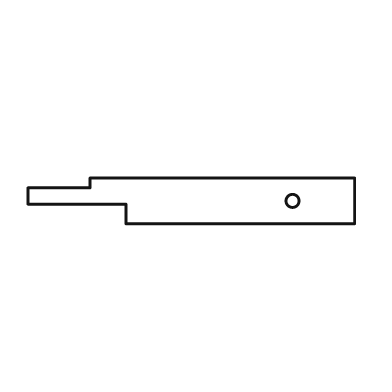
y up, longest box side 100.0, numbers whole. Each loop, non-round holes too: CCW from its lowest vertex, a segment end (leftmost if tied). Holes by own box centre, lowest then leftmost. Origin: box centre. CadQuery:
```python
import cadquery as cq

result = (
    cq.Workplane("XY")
    .moveTo(-20.0, -7.0)
    .lineTo(50.0, -7.0)
    .lineTo(50.0, 7.0)
    .lineTo(-31.0, 7.0)
    .lineTo(-31.0, 4.0)
    .lineTo(-50.0, 4.0)
    .lineTo(-50.0, -1.0)
    .lineTo(-20.0, -1.0)
    .close()
    .moveTo(31.0, 0.0)
    .circle(2.0)
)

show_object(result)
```